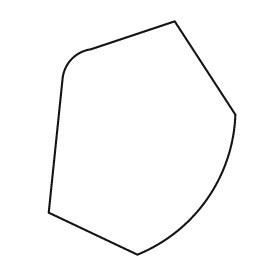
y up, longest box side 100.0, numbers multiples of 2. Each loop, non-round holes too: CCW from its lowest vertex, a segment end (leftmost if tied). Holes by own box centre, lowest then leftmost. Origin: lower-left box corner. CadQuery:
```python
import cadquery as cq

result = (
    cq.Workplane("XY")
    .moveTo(38.0, 0.0)
    .threePointArc((68.0, 24.0), (80.0, 60.0))
    .lineTo(54.0, 100.0)
    .lineTo(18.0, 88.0)
    .threePointArc((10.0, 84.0), (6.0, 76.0))
    .lineTo(0.0, 18.0)
    .close()
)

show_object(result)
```